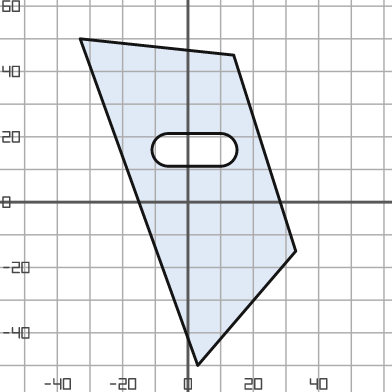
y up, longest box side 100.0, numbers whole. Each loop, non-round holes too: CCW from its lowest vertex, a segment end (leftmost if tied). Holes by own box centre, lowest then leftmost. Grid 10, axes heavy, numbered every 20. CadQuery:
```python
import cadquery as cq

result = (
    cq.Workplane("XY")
    .moveTo(3.0, -50.0)
    .lineTo(33.0, -15.0)
    .lineTo(14.0, 45.0)
    .lineTo(-33.0, 50.0)
    .close()
    .moveTo(-6.0, 11.0)
    .lineTo(10.0, 11.0)
    .threePointArc((15.0, 16.0), (10.0, 21.0))
    .lineTo(-6.0, 21.0)
    .threePointArc((-11.0, 16.0), (-6.0, 11.0))
    .close()
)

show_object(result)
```